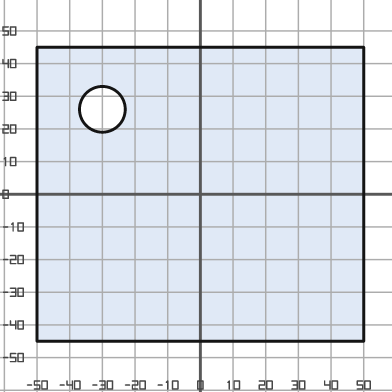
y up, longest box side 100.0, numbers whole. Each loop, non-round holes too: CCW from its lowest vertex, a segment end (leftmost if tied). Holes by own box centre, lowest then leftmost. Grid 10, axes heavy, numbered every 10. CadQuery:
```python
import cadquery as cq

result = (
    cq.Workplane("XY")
    .moveTo(-50.0, -45.0)
    .lineTo(50.0, -45.0)
    .lineTo(50.0, 45.0)
    .lineTo(-50.0, 45.0)
    .close()
    .moveTo(-30.0, 26.0)
    .circle(7.0)
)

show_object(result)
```